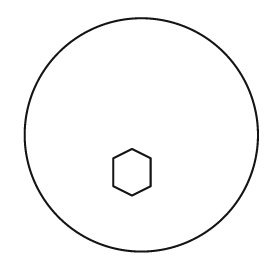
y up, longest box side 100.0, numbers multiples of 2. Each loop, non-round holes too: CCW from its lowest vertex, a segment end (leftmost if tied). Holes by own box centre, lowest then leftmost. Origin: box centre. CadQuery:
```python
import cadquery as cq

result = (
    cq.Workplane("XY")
    .moveTo(0.0, 0.0)
    .circle(50.0)
    .moveTo(-4.0, -26.0)
    .lineTo(4.0, -22.0)
    .lineTo(4.0, -10.0)
    .lineTo(-4.0, -6.0)
    .lineTo(-12.0, -10.0)
    .lineTo(-12.0, -22.0)
    .close()
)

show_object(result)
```